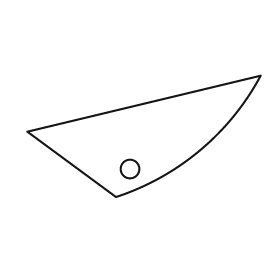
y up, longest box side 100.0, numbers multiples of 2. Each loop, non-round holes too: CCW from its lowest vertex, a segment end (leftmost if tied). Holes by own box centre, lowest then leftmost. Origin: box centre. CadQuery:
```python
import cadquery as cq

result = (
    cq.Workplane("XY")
    .moveTo(-12.0, -26.0)
    .threePointArc((24.0, -6.0), (50.0, 26.0))
    .lineTo(-50.0, 2.0)
    .close()
    .moveTo(-6.0, -14.0)
    .circle(4.0)
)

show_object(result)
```